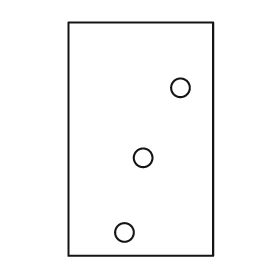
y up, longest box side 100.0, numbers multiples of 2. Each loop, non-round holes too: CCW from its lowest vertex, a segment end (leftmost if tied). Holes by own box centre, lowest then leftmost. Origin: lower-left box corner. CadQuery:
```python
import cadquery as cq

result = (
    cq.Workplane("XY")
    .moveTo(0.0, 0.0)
    .lineTo(62.0, 0.0)
    .lineTo(62.0, 100.0)
    .lineTo(0.0, 100.0)
    .close()
    .moveTo(24.0, 10.0)
    .circle(4.0)
    .moveTo(32.0, 42.0)
    .circle(4.0)
    .moveTo(48.0, 72.0)
    .circle(4.0)
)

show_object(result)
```